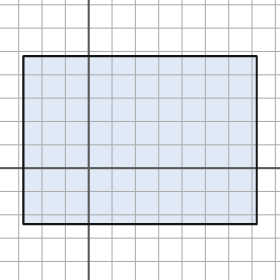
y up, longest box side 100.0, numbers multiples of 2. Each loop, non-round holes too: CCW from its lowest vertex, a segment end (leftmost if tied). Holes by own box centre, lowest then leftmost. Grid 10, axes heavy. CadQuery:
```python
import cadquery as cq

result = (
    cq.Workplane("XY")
    .moveTo(-28.0, -24.0)
    .lineTo(72.0, -24.0)
    .lineTo(72.0, 48.0)
    .lineTo(-28.0, 48.0)
    .close()
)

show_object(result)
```